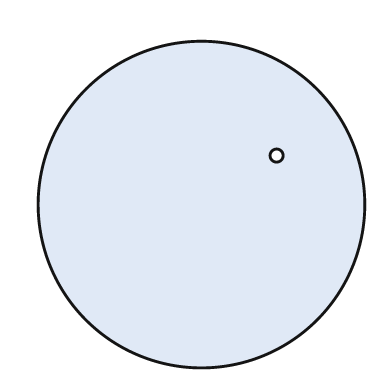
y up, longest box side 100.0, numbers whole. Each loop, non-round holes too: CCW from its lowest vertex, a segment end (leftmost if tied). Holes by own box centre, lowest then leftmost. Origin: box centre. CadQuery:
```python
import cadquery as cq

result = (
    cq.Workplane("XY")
    .moveTo(0.0, 0.0)
    .circle(50.0)
    .moveTo(23.0, 15.0)
    .circle(2.0)
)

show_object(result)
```